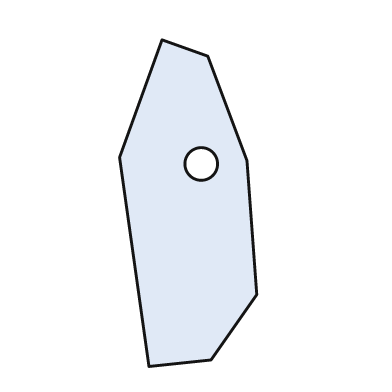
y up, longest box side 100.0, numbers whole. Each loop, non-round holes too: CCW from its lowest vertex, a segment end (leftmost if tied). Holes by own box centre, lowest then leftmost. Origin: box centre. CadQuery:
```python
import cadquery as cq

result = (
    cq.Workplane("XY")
    .moveTo(-12.0, -50.0)
    .lineTo(7.0, -48.0)
    .lineTo(21.0, -28.0)
    .lineTo(18.0, 13.0)
    .lineTo(6.0, 45.0)
    .lineTo(-8.0, 50.0)
    .lineTo(-21.0, 14.0)
    .close()
    .moveTo(4.0, 12.0)
    .circle(5.0)
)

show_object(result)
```